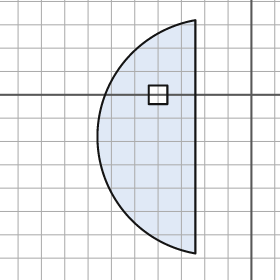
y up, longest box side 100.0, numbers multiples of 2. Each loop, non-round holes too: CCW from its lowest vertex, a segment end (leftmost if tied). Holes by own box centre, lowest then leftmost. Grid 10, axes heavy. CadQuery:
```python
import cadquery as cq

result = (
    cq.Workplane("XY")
    .moveTo(-24.0, -68.0)
    .lineTo(-24.0, 32.0)
    .threePointArc((-66.0, -18.0), (-24.0, -68.0))
    .close()
    .moveTo(-44.0, -4.0)
    .lineTo(-36.0, -4.0)
    .lineTo(-36.0, 4.0)
    .lineTo(-44.0, 4.0)
    .close()
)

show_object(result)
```